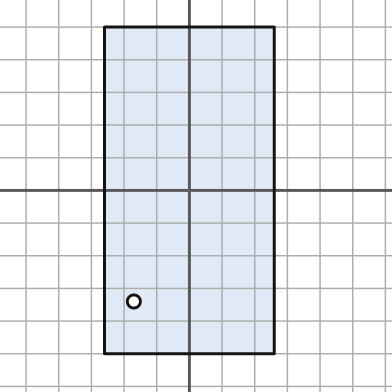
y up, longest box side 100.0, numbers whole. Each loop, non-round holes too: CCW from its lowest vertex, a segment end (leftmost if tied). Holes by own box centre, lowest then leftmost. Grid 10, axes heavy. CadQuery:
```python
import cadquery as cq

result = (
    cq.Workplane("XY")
    .moveTo(-26.0, -50.0)
    .lineTo(26.0, -50.0)
    .lineTo(26.0, 50.0)
    .lineTo(-26.0, 50.0)
    .close()
    .moveTo(-17.0, -34.0)
    .circle(2.0)
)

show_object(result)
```